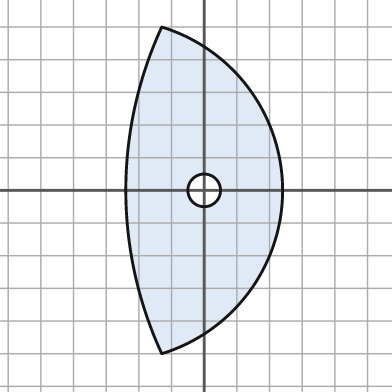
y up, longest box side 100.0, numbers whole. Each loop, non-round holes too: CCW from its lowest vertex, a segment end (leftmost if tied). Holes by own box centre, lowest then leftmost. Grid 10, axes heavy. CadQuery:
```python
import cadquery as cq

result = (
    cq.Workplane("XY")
    .moveTo(-13.0, -50.0)
    .threePointArc((24.0, 0.0), (-13.0, 50.0))
    .threePointArc((-24.0, 0.0), (-13.0, -50.0))
    .close()
    .moveTo(0.0, 0.0)
    .circle(5.0)
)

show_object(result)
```